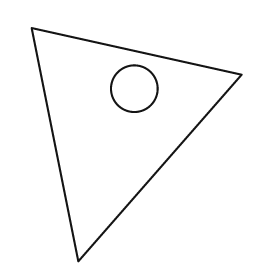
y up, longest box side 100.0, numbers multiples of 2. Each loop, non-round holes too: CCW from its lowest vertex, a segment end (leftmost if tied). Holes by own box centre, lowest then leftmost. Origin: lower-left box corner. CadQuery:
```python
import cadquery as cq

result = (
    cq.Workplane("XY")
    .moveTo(20.0, 0.0)
    .lineTo(90.0, 80.0)
    .lineTo(0.0, 100.0)
    .close()
    .moveTo(44.0, 74.0)
    .circle(10.0)
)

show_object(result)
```